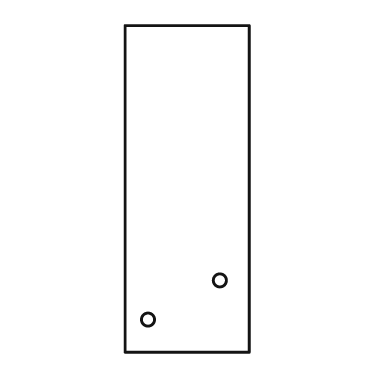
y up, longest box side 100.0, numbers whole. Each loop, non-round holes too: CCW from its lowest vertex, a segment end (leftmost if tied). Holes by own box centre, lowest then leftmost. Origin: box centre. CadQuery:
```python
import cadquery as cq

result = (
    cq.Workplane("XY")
    .moveTo(-19.0, -50.0)
    .lineTo(19.0, -50.0)
    .lineTo(19.0, 50.0)
    .lineTo(-19.0, 50.0)
    .close()
    .moveTo(-12.0, -40.0)
    .circle(2.0)
    .moveTo(10.0, -28.0)
    .circle(2.0)
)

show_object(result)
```